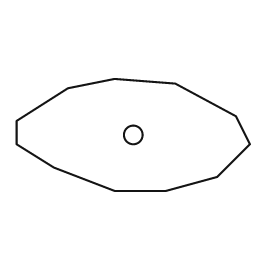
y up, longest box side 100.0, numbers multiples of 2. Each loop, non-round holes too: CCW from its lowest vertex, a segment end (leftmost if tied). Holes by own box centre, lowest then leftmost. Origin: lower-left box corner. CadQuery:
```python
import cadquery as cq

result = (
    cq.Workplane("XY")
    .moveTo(42.0, 0.0)
    .lineTo(64.0, 0.0)
    .lineTo(86.0, 6.0)
    .lineTo(100.0, 20.0)
    .lineTo(94.0, 32.0)
    .lineTo(68.0, 46.0)
    .lineTo(42.0, 48.0)
    .lineTo(22.0, 44.0)
    .lineTo(0.0, 30.0)
    .lineTo(0.0, 20.0)
    .lineTo(16.0, 10.0)
    .close()
    .moveTo(50.0, 24.0)
    .circle(4.0)
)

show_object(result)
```